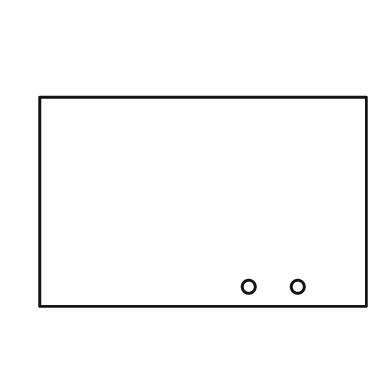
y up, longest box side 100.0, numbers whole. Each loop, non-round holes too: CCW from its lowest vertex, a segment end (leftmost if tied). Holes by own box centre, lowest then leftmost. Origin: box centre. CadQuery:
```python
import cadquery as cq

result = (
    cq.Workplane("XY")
    .moveTo(-50.0, -32.0)
    .lineTo(50.0, -32.0)
    .lineTo(50.0, 32.0)
    .lineTo(-50.0, 32.0)
    .close()
    .moveTo(14.0, -26.0)
    .circle(2.0)
    .moveTo(29.0, -26.0)
    .circle(2.0)
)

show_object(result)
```